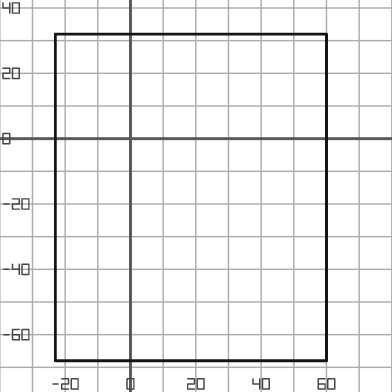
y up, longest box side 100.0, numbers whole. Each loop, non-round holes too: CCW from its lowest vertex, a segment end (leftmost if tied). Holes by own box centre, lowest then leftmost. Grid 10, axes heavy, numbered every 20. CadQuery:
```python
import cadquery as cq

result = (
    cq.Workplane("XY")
    .moveTo(-23.0, -68.0)
    .lineTo(60.0, -68.0)
    .lineTo(60.0, 32.0)
    .lineTo(-23.0, 32.0)
    .close()
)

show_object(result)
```